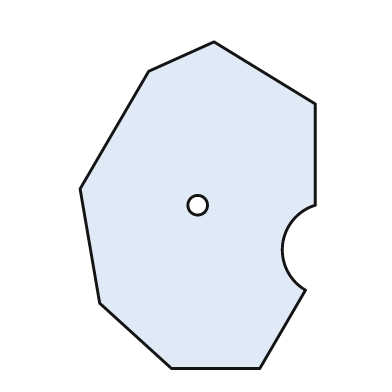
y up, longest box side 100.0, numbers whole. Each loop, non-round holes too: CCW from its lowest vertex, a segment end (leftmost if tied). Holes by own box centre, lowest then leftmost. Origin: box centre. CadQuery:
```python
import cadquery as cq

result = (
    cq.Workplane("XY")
    .moveTo(-8.0, -50.0)
    .lineTo(19.0, -50.0)
    .lineTo(33.0, -26.0)
    .threePointArc((26.0, -12.0), (36.0, 0.0))
    .lineTo(36.0, 31.0)
    .lineTo(5.0, 50.0)
    .lineTo(-15.0, 41.0)
    .lineTo(-36.0, 5.0)
    .lineTo(-30.0, -30.0)
    .close()
    .moveTo(0.0, 0.0)
    .circle(3.0)
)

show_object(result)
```